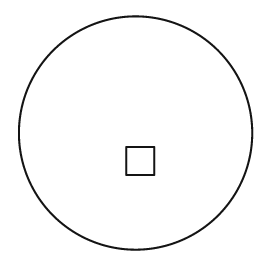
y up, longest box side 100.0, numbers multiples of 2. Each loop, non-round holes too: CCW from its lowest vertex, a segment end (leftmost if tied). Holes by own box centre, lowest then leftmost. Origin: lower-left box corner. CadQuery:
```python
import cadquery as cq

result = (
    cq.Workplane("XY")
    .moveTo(50.0, 50.0)
    .circle(50.0)
    .moveTo(46.0, 32.0)
    .lineTo(58.0, 32.0)
    .lineTo(58.0, 44.0)
    .lineTo(46.0, 44.0)
    .close()
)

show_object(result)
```